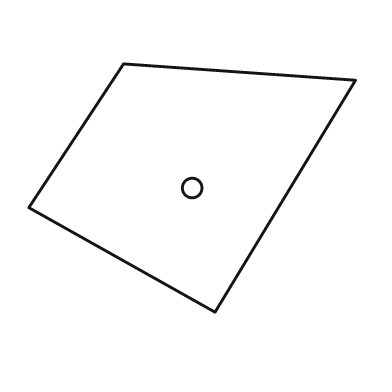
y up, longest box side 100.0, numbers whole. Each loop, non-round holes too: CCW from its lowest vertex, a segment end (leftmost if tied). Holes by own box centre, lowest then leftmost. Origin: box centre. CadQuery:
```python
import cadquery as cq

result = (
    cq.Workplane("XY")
    .moveTo(7.0, -38.0)
    .lineTo(50.0, 33.0)
    .lineTo(-21.0, 38.0)
    .lineTo(-50.0, -6.0)
    .close()
    .moveTo(0.0, 0.0)
    .circle(3.0)
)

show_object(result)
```